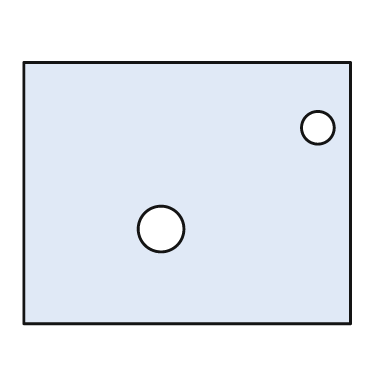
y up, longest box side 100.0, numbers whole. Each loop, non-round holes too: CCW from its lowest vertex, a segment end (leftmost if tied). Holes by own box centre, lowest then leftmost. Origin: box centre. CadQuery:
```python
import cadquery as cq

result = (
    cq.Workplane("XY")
    .moveTo(-50.0, -40.0)
    .lineTo(50.0, -40.0)
    .lineTo(50.0, 40.0)
    .lineTo(-50.0, 40.0)
    .close()
    .moveTo(-8.0, -11.0)
    .circle(7.0)
    .moveTo(40.0, 20.0)
    .circle(5.0)
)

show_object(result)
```